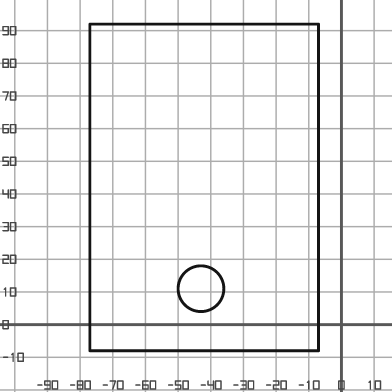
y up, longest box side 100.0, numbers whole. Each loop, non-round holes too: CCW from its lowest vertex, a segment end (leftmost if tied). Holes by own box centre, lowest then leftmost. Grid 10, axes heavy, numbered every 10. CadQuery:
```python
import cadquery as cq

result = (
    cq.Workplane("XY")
    .moveTo(-77.0, -8.0)
    .lineTo(-7.0, -8.0)
    .lineTo(-7.0, 92.0)
    .lineTo(-77.0, 92.0)
    .close()
    .moveTo(-43.0, 11.0)
    .circle(7.0)
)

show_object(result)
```